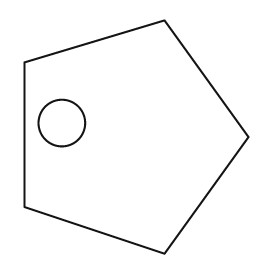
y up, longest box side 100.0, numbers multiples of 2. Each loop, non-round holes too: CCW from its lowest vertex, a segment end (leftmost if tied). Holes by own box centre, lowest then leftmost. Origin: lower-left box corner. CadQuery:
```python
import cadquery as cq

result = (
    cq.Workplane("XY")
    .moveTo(60.0, 0.0)
    .lineTo(96.0, 50.0)
    .lineTo(60.0, 100.0)
    .lineTo(0.0, 82.0)
    .lineTo(0.0, 20.0)
    .close()
    .moveTo(16.0, 56.0)
    .circle(10.0)
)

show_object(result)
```